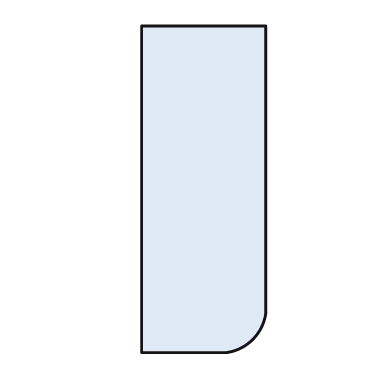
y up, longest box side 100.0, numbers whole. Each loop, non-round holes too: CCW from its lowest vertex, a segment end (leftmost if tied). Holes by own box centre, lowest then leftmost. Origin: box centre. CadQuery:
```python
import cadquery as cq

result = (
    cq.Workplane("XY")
    .moveTo(-19.0, -50.0)
    .lineTo(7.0, -50.0)
    .threePointArc((15.0, -46.0), (19.0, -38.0))
    .lineTo(19.0, 50.0)
    .lineTo(-19.0, 50.0)
    .close()
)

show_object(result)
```